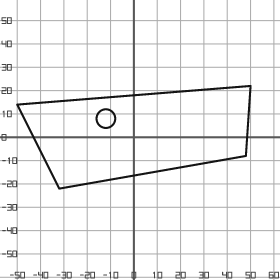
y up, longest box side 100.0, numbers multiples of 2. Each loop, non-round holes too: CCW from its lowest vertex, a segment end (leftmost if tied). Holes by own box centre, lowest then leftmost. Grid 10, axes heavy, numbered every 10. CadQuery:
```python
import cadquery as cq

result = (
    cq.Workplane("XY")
    .moveTo(-32.0, -22.0)
    .lineTo(48.0, -8.0)
    .lineTo(50.0, 22.0)
    .lineTo(-50.0, 14.0)
    .close()
    .moveTo(-12.0, 8.0)
    .circle(4.0)
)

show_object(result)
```